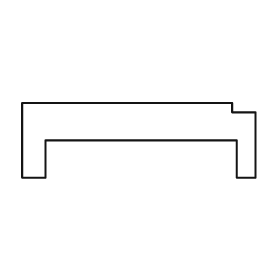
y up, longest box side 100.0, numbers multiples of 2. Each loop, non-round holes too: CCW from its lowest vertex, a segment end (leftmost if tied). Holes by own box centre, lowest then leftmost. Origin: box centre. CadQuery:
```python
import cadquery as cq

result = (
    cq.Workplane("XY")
    .moveTo(-50.0, -16.0)
    .lineTo(-40.0, -16.0)
    .lineTo(-40.0, 0.0)
    .lineTo(42.0, 0.0)
    .lineTo(42.0, -16.0)
    .lineTo(50.0, -16.0)
    .lineTo(50.0, 12.0)
    .lineTo(40.0, 12.0)
    .lineTo(40.0, 16.0)
    .lineTo(-50.0, 16.0)
    .close()
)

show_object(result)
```